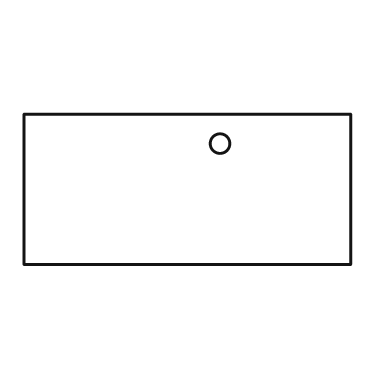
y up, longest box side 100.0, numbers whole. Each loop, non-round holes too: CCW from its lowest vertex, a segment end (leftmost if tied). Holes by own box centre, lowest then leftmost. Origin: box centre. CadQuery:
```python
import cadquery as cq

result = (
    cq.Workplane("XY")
    .moveTo(-50.0, -23.0)
    .lineTo(50.0, -23.0)
    .lineTo(50.0, 23.0)
    .lineTo(-50.0, 23.0)
    .close()
    .moveTo(10.0, 14.0)
    .circle(3.0)
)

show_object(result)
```